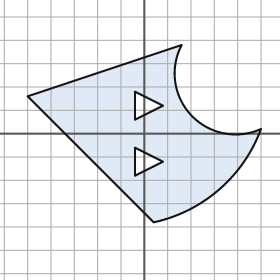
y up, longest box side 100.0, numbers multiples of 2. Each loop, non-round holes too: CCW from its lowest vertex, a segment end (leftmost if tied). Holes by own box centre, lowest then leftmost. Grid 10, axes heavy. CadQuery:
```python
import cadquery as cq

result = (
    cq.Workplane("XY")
    .moveTo(4.0, -38.0)
    .threePointArc((32.0, -24.0), (50.0, 2.0))
    .threePointArc((20.0, 8.0), (16.0, 38.0))
    .lineTo(-50.0, 16.0)
    .close()
    .moveTo(-4.0, -18.0)
    .lineTo(8.0, -12.0)
    .lineTo(-4.0, -6.0)
    .close()
    .moveTo(-4.0, 6.0)
    .lineTo(8.0, 12.0)
    .lineTo(-4.0, 18.0)
    .close()
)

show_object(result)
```